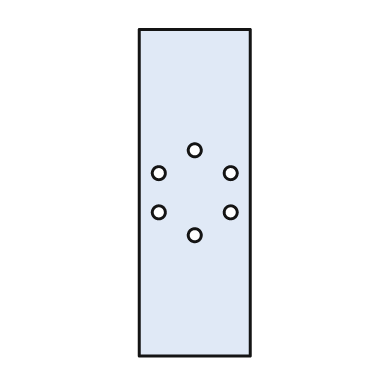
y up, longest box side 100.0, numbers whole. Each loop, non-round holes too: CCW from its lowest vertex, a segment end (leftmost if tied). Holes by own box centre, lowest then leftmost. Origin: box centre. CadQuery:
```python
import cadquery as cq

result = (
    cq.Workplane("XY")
    .moveTo(-17.0, -50.0)
    .lineTo(17.0, -50.0)
    .lineTo(17.0, 50.0)
    .lineTo(-17.0, 50.0)
    .close()
    .moveTo(0.0, -13.0)
    .circle(2.0)
    .moveTo(-11.0, -6.0)
    .circle(2.0)
    .moveTo(11.0, -6.0)
    .circle(2.0)
    .moveTo(-11.0, 6.0)
    .circle(2.0)
    .moveTo(11.0, 6.0)
    .circle(2.0)
    .moveTo(0.0, 13.0)
    .circle(2.0)
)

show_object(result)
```